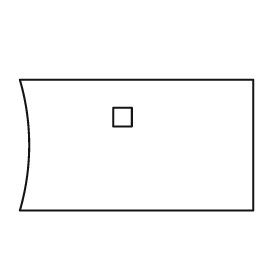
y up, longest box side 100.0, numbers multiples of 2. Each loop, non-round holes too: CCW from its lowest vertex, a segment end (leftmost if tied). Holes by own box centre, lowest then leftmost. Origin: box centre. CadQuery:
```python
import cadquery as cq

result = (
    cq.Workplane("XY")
    .moveTo(-50.0, -28.0)
    .lineTo(50.0, -28.0)
    .lineTo(50.0, 28.0)
    .lineTo(-50.0, 28.0)
    .threePointArc((-46.0, 0.0), (-50.0, -28.0))
    .close()
    .moveTo(-10.0, 8.0)
    .lineTo(-2.0, 8.0)
    .lineTo(-2.0, 16.0)
    .lineTo(-10.0, 16.0)
    .close()
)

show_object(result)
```